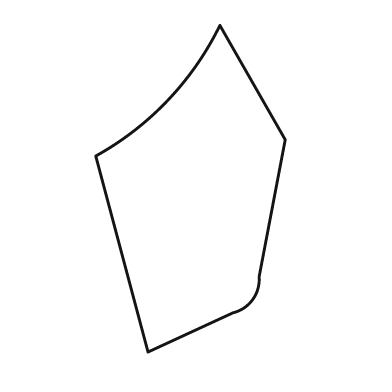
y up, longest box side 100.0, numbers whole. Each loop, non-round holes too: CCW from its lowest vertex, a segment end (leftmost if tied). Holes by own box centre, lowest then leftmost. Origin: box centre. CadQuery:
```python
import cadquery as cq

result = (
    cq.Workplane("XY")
    .moveTo(-13.0, -50.0)
    .lineTo(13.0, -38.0)
    .threePointArc((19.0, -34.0), (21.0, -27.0))
    .lineTo(29.0, 15.0)
    .lineTo(9.0, 50.0)
    .threePointArc((-7.0, 27.0), (-29.0, 10.0))
    .close()
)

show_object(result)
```